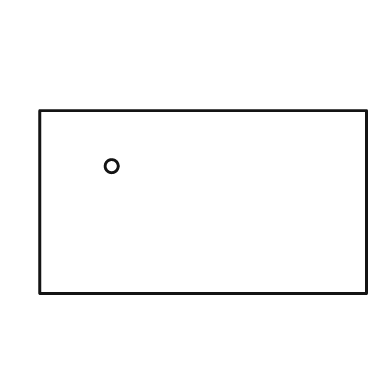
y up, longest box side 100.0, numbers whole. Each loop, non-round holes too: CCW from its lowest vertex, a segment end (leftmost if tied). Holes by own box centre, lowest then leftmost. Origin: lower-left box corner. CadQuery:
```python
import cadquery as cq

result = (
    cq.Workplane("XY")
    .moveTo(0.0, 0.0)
    .lineTo(100.0, 0.0)
    .lineTo(100.0, 56.0)
    .lineTo(0.0, 56.0)
    .close()
    .moveTo(22.0, 39.0)
    .circle(2.0)
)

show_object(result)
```